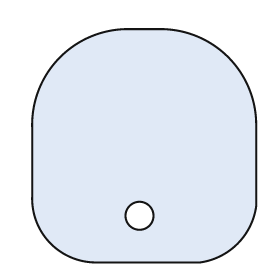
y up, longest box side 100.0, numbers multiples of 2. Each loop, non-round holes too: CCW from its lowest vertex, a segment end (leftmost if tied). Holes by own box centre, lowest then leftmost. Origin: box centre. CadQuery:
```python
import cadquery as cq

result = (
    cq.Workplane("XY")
    .moveTo(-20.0, -50.0)
    .lineTo(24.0, -50.0)
    .threePointArc((40.0, -42.0), (48.0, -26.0))
    .lineTo(48.0, 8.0)
    .threePointArc((36.0, 38.0), (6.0, 50.0))
    .lineTo(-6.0, 50.0)
    .threePointArc((-36.0, 38.0), (-48.0, 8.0))
    .lineTo(-48.0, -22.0)
    .threePointArc((-40.0, -42.0), (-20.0, -50.0))
    .close()
    .moveTo(-2.0, -30.0)
    .circle(6.0)
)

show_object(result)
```